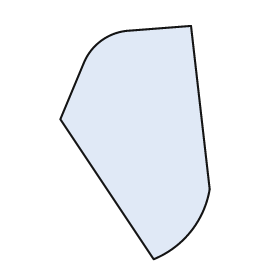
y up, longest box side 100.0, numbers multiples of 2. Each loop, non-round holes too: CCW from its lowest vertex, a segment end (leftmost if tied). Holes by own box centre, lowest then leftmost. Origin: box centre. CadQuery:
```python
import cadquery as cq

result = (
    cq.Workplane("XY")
    .moveTo(8.0, -50.0)
    .threePointArc((24.0, -38.0), (32.0, -20.0))
    .lineTo(24.0, 50.0)
    .lineTo(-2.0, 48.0)
    .threePointArc((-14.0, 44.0), (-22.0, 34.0))
    .lineTo(-32.0, 10.0)
    .close()
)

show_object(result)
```